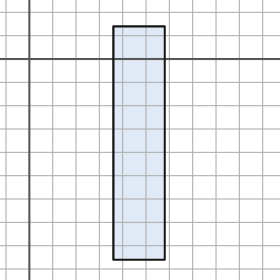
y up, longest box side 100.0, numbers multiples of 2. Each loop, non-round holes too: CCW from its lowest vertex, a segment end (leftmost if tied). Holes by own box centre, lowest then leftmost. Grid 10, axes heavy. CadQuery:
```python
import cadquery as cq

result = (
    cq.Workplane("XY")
    .moveTo(36.0, -86.0)
    .lineTo(58.0, -86.0)
    .lineTo(58.0, 14.0)
    .lineTo(36.0, 14.0)
    .close()
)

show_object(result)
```